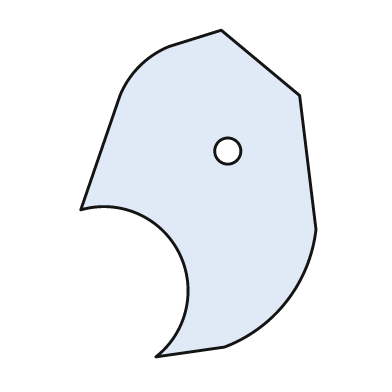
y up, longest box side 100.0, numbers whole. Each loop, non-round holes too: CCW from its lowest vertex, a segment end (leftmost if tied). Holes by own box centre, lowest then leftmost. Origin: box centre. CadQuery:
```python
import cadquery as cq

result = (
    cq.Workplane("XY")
    .moveTo(-13.0, -50.0)
    .lineTo(8.0, -47.0)
    .threePointArc((27.0, -33.0), (36.0, -11.0))
    .lineTo(31.0, 30.0)
    .lineTo(7.0, 50.0)
    .lineTo(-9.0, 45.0)
    .threePointArc((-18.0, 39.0), (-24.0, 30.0))
    .lineTo(-36.0, -5.0)
    .threePointArc((-6.0, -18.0), (-13.0, -50.0))
    .close()
    .moveTo(9.0, 13.0)
    .circle(4.0)
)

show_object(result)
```